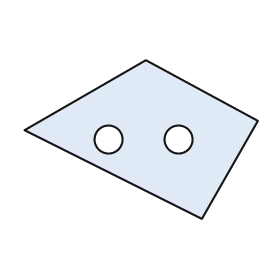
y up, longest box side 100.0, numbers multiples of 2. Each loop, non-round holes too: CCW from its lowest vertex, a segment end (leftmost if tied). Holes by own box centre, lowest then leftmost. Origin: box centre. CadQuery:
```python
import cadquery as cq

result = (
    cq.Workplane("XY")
    .moveTo(26.0, -34.0)
    .lineTo(50.0, 8.0)
    .lineTo(2.0, 34.0)
    .lineTo(-50.0, 4.0)
    .close()
    .moveTo(-14.0, 0.0)
    .circle(6.0)
    .moveTo(16.0, 0.0)
    .circle(6.0)
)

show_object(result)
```